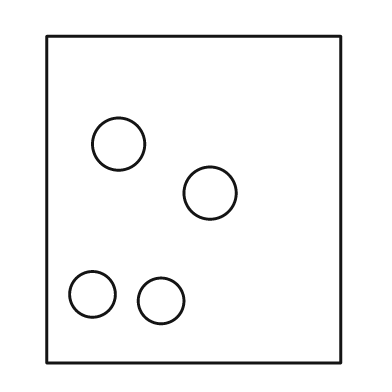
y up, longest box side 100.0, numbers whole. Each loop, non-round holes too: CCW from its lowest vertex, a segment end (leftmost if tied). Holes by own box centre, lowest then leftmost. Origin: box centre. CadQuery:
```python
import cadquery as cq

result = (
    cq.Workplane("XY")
    .moveTo(-45.0, -50.0)
    .lineTo(45.0, -50.0)
    .lineTo(45.0, 50.0)
    .lineTo(-45.0, 50.0)
    .close()
    .moveTo(-10.0, -31.0)
    .circle(7.0)
    .moveTo(-31.0, -29.0)
    .circle(7.0)
    .moveTo(5.0, 2.0)
    .circle(8.0)
    .moveTo(-23.0, 17.0)
    .circle(8.0)
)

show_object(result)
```